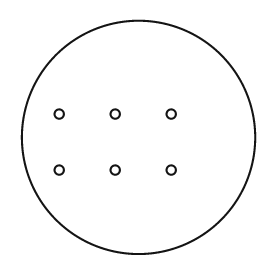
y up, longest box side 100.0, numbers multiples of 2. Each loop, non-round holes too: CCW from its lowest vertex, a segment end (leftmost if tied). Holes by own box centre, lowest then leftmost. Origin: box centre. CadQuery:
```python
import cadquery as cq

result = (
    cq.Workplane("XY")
    .moveTo(0.0, 0.0)
    .circle(50.0)
    .moveTo(-34.0, -14.0)
    .circle(2.0)
    .moveTo(-10.0, -14.0)
    .circle(2.0)
    .moveTo(14.0, -14.0)
    .circle(2.0)
    .moveTo(-34.0, 10.0)
    .circle(2.0)
    .moveTo(-10.0, 10.0)
    .circle(2.0)
    .moveTo(14.0, 10.0)
    .circle(2.0)
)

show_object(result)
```